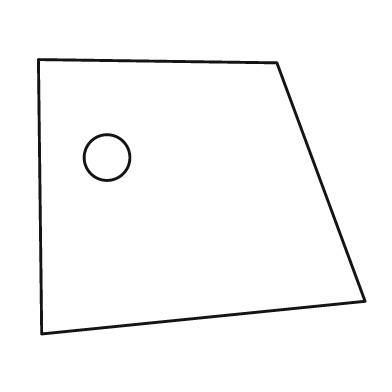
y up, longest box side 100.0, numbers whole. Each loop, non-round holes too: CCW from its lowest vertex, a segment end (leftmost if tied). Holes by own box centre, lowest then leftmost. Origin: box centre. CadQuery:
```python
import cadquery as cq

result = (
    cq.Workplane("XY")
    .moveTo(-49.0, -42.0)
    .lineTo(50.0, -32.0)
    .lineTo(23.0, 41.0)
    .lineTo(-50.0, 42.0)
    .close()
    .moveTo(-29.0, 12.0)
    .circle(7.0)
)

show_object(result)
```